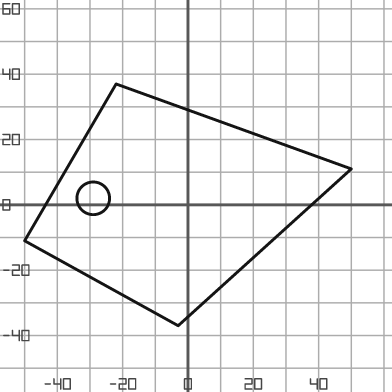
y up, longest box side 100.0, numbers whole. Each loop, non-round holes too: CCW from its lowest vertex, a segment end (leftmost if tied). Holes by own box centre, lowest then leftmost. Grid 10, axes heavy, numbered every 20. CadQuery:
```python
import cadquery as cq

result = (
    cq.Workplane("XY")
    .moveTo(-3.0, -37.0)
    .lineTo(50.0, 11.0)
    .lineTo(-22.0, 37.0)
    .lineTo(-50.0, -11.0)
    .close()
    .moveTo(-29.0, 2.0)
    .circle(5.0)
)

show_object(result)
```